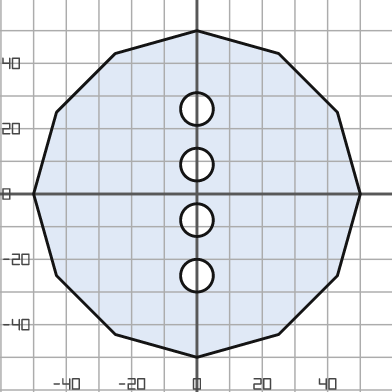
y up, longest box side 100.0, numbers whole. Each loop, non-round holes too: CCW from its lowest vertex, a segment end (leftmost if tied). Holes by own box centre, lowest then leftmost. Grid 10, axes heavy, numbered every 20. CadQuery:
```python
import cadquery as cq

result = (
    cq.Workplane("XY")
    .moveTo(0.0, -50.0)
    .lineTo(25.0, -43.0)
    .lineTo(43.0, -25.0)
    .lineTo(50.0, 0.0)
    .lineTo(43.0, 25.0)
    .lineTo(25.0, 43.0)
    .lineTo(0.0, 50.0)
    .lineTo(-25.0, 43.0)
    .lineTo(-43.0, 25.0)
    .lineTo(-50.0, 0.0)
    .lineTo(-43.0, -25.0)
    .lineTo(-25.0, -43.0)
    .close()
    .moveTo(0.0, -25.0)
    .circle(5.0)
    .moveTo(0.0, -8.0)
    .circle(5.0)
    .moveTo(0.0, 9.0)
    .circle(5.0)
    .moveTo(0.0, 26.0)
    .circle(5.0)
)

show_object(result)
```